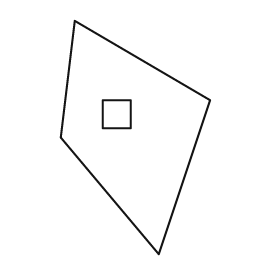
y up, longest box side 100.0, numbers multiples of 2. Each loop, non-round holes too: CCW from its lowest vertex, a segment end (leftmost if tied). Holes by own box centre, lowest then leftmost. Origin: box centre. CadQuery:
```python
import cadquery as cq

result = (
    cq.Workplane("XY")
    .moveTo(10.0, -50.0)
    .lineTo(32.0, 16.0)
    .lineTo(-26.0, 50.0)
    .lineTo(-32.0, 0.0)
    .close()
    .moveTo(-14.0, 4.0)
    .lineTo(-2.0, 4.0)
    .lineTo(-2.0, 16.0)
    .lineTo(-14.0, 16.0)
    .close()
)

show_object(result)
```